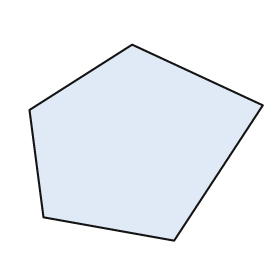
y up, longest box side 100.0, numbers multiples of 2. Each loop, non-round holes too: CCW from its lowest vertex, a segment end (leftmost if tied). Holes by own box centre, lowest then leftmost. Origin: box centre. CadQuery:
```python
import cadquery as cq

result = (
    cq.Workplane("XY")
    .moveTo(12.0, -42.0)
    .lineTo(50.0, 16.0)
    .lineTo(-6.0, 42.0)
    .lineTo(-50.0, 14.0)
    .lineTo(-44.0, -32.0)
    .close()
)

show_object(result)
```